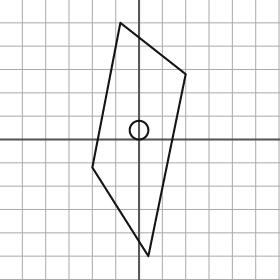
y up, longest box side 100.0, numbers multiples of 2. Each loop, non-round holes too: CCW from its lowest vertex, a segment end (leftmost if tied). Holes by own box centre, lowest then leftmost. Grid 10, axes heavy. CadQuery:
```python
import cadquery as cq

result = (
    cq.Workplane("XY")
    .moveTo(4.0, -50.0)
    .lineTo(20.0, 28.0)
    .lineTo(-8.0, 50.0)
    .lineTo(-20.0, -12.0)
    .close()
    .moveTo(0.0, 4.0)
    .circle(4.0)
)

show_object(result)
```